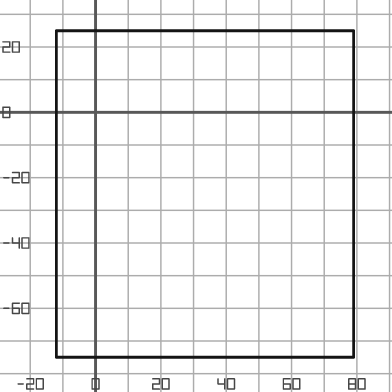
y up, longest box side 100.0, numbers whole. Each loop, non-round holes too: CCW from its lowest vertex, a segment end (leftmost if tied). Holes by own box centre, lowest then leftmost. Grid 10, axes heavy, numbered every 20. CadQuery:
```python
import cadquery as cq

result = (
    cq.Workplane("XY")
    .moveTo(-12.0, -75.0)
    .lineTo(79.0, -75.0)
    .lineTo(79.0, 25.0)
    .lineTo(-12.0, 25.0)
    .close()
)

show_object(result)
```